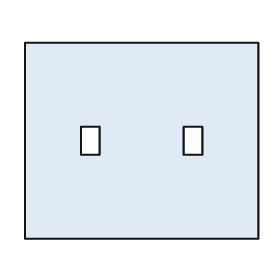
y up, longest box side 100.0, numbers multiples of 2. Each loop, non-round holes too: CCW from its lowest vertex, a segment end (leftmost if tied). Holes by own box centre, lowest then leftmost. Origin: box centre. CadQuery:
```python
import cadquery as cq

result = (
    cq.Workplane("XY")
    .moveTo(-50.0, -42.0)
    .lineTo(50.0, -42.0)
    .lineTo(50.0, 42.0)
    .lineTo(-50.0, 42.0)
    .close()
    .moveTo(-26.0, -6.0)
    .lineTo(-18.0, -6.0)
    .lineTo(-18.0, 6.0)
    .lineTo(-26.0, 6.0)
    .close()
    .moveTo(18.0, -6.0)
    .lineTo(26.0, -6.0)
    .lineTo(26.0, 6.0)
    .lineTo(18.0, 6.0)
    .close()
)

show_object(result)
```